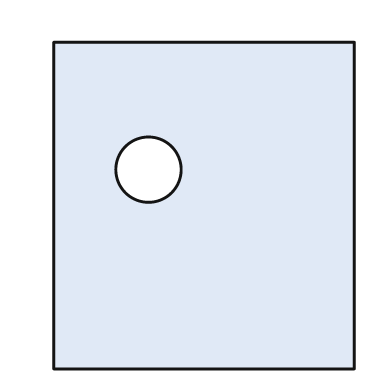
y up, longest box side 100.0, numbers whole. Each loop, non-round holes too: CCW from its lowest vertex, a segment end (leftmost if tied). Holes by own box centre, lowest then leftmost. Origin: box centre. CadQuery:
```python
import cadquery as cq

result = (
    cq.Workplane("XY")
    .moveTo(-46.0, -50.0)
    .lineTo(46.0, -50.0)
    .lineTo(46.0, 50.0)
    .lineTo(-46.0, 50.0)
    .close()
    .moveTo(-17.0, 11.0)
    .circle(10.0)
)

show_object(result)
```